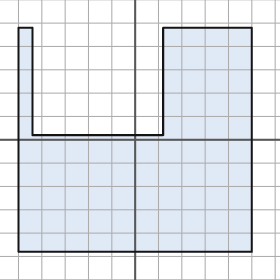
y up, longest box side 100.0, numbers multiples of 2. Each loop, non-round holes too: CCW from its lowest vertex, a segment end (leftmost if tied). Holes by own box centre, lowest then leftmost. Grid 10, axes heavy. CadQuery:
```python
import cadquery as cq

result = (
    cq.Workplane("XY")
    .moveTo(-50.0, -48.0)
    .lineTo(50.0, -48.0)
    .lineTo(50.0, 48.0)
    .lineTo(12.0, 48.0)
    .lineTo(12.0, 2.0)
    .lineTo(-44.0, 2.0)
    .lineTo(-44.0, 48.0)
    .lineTo(-50.0, 48.0)
    .close()
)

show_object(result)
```